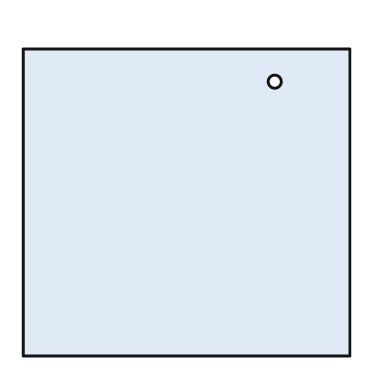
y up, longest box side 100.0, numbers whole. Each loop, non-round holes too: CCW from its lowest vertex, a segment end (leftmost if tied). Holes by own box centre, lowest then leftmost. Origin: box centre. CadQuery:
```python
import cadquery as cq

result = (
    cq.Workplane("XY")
    .moveTo(-50.0, -47.0)
    .lineTo(50.0, -47.0)
    .lineTo(50.0, 47.0)
    .lineTo(-50.0, 47.0)
    .close()
    .moveTo(27.0, 37.0)
    .circle(2.0)
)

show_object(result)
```